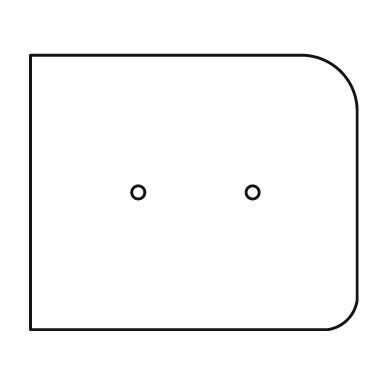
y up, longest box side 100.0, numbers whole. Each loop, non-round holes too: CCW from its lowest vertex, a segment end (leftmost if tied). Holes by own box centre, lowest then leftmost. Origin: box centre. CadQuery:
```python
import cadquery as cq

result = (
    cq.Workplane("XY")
    .moveTo(-50.0, -42.0)
    .lineTo(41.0, -42.0)
    .threePointArc((47.0, -39.0), (50.0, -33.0))
    .lineTo(50.0, 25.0)
    .threePointArc((45.0, 37.0), (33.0, 42.0))
    .lineTo(-50.0, 42.0)
    .close()
    .moveTo(-17.0, 0.0)
    .circle(2.0)
    .moveTo(18.0, 0.0)
    .circle(2.0)
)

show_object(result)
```